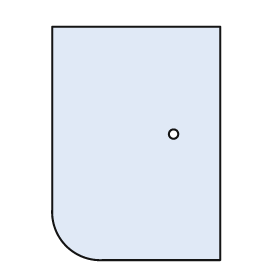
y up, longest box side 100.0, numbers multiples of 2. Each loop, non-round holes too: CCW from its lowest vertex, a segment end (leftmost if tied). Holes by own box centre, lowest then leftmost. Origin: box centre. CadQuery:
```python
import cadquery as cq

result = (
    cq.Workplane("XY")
    .moveTo(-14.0, -50.0)
    .lineTo(36.0, -50.0)
    .lineTo(36.0, 50.0)
    .lineTo(-36.0, 50.0)
    .lineTo(-36.0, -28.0)
    .threePointArc((-30.0, -44.0), (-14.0, -50.0))
    .close()
    .moveTo(16.0, 4.0)
    .circle(2.0)
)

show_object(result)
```